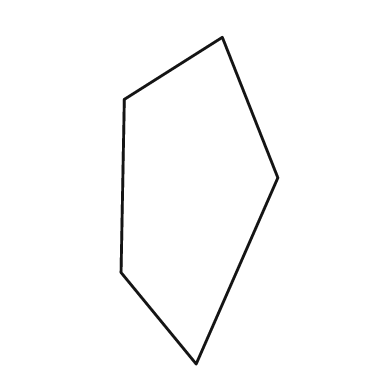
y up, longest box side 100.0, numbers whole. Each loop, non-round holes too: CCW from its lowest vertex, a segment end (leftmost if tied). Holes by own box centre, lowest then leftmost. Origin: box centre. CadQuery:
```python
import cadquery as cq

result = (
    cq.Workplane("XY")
    .moveTo(-1.0, -50.0)
    .lineTo(24.0, 7.0)
    .lineTo(7.0, 50.0)
    .lineTo(-23.0, 31.0)
    .lineTo(-24.0, -22.0)
    .close()
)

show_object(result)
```